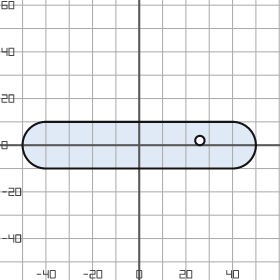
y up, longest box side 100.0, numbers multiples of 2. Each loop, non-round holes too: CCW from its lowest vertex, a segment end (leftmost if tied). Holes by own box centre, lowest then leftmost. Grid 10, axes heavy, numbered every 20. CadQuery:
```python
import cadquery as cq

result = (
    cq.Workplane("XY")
    .moveTo(-40.0, -10.0)
    .lineTo(40.0, -10.0)
    .threePointArc((50.0, 0.0), (40.0, 10.0))
    .lineTo(-40.0, 10.0)
    .threePointArc((-50.0, 0.0), (-40.0, -10.0))
    .close()
    .moveTo(26.0, 2.0)
    .circle(2.0)
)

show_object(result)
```